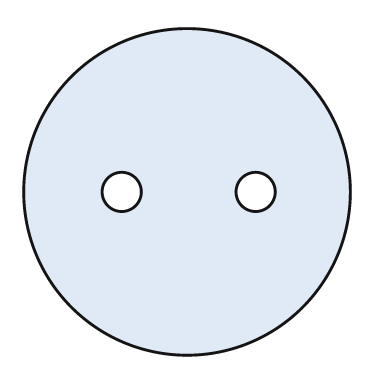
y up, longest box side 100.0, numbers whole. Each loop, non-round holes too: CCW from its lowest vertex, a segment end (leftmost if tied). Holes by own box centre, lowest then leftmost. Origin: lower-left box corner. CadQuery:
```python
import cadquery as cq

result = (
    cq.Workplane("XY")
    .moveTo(50.0, 50.0)
    .circle(50.0)
    .moveTo(30.0, 50.0)
    .circle(6.0)
    .moveTo(71.0, 50.0)
    .circle(6.0)
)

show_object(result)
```